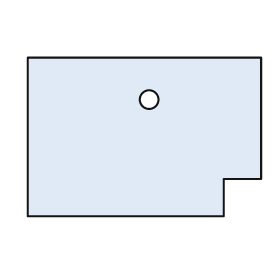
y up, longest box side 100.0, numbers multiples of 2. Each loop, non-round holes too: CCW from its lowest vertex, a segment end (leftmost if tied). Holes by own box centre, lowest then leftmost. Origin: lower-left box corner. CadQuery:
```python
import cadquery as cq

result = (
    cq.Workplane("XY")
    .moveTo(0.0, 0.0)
    .lineTo(84.0, 0.0)
    .lineTo(84.0, 16.0)
    .lineTo(100.0, 16.0)
    .lineTo(100.0, 68.0)
    .lineTo(0.0, 68.0)
    .close()
    .moveTo(52.0, 50.0)
    .circle(4.0)
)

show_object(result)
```